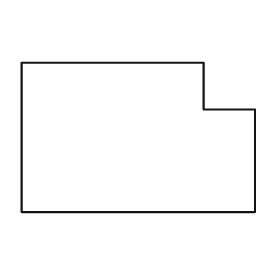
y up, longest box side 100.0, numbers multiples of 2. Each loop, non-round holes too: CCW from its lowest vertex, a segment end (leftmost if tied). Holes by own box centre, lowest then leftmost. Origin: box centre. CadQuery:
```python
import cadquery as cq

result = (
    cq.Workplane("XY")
    .moveTo(-50.0, -32.0)
    .lineTo(50.0, -32.0)
    .lineTo(50.0, 12.0)
    .lineTo(28.0, 12.0)
    .lineTo(28.0, 32.0)
    .lineTo(-50.0, 32.0)
    .close()
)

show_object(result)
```